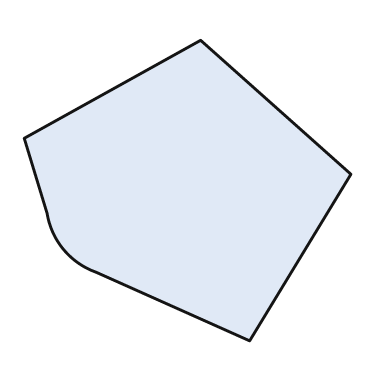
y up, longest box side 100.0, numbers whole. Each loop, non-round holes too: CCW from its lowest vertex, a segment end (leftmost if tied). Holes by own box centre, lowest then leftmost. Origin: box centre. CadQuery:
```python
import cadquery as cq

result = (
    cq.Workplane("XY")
    .moveTo(19.0, -46.0)
    .lineTo(50.0, 5.0)
    .lineTo(4.0, 46.0)
    .lineTo(-50.0, 16.0)
    .lineTo(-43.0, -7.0)
    .threePointArc((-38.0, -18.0), (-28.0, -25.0))
    .close()
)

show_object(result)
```